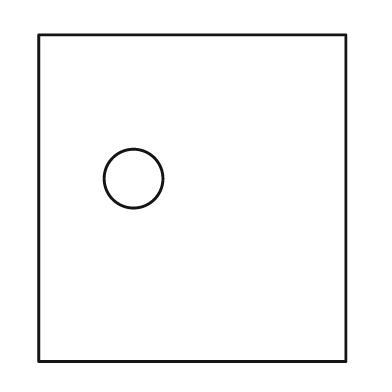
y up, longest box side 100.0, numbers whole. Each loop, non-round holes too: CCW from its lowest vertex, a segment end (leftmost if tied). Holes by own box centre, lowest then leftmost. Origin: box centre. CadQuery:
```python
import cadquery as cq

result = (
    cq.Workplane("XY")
    .moveTo(-47.0, -50.0)
    .lineTo(47.0, -50.0)
    .lineTo(47.0, 50.0)
    .lineTo(-47.0, 50.0)
    .close()
    .moveTo(-18.0, 6.0)
    .circle(9.0)
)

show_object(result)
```